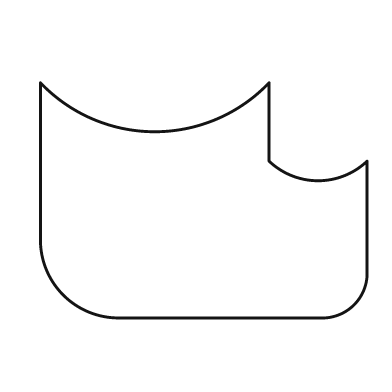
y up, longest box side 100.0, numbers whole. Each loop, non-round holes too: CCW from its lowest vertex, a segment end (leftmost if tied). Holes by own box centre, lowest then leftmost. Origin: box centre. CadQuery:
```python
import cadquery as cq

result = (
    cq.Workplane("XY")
    .moveTo(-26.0, -36.0)
    .lineTo(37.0, -36.0)
    .threePointArc((46.0, -32.0), (50.0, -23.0))
    .lineTo(50.0, 12.0)
    .threePointArc((35.0, 6.0), (20.0, 12.0))
    .lineTo(20.0, 36.0)
    .threePointArc((-15.0, 21.0), (-50.0, 36.0))
    .lineTo(-50.0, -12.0)
    .threePointArc((-43.0, -29.0), (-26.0, -36.0))
    .close()
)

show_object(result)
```